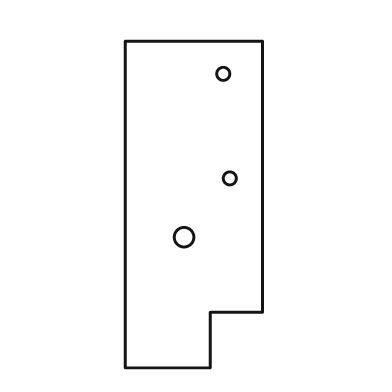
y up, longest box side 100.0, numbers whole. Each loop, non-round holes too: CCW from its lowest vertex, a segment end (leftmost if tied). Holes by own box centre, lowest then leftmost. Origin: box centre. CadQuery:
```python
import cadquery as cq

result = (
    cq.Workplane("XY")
    .moveTo(-21.0, -50.0)
    .lineTo(5.0, -50.0)
    .lineTo(5.0, -33.0)
    .lineTo(21.0, -33.0)
    .lineTo(21.0, 50.0)
    .lineTo(-21.0, 50.0)
    .close()
    .moveTo(-3.0, -10.0)
    .circle(3.0)
    .moveTo(11.0, 8.0)
    .circle(2.0)
    .moveTo(9.0, 40.0)
    .circle(2.0)
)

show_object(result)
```